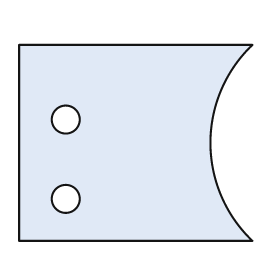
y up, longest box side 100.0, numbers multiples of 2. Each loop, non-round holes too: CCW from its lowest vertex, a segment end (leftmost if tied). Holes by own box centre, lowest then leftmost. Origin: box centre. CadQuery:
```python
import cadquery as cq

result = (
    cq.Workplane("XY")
    .moveTo(-50.0, -42.0)
    .lineTo(50.0, -42.0)
    .threePointArc((32.0, 0.0), (50.0, 42.0))
    .lineTo(-50.0, 42.0)
    .close()
    .moveTo(-30.0, -24.0)
    .circle(6.0)
    .moveTo(-30.0, 10.0)
    .circle(6.0)
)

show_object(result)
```